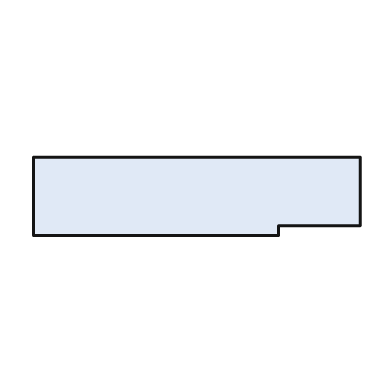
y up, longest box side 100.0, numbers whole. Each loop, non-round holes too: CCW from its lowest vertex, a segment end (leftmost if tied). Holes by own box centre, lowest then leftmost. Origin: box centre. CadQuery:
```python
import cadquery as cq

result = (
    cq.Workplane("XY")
    .moveTo(-50.0, -12.0)
    .lineTo(25.0, -12.0)
    .lineTo(25.0, -9.0)
    .lineTo(50.0, -9.0)
    .lineTo(50.0, 12.0)
    .lineTo(-50.0, 12.0)
    .close()
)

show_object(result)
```